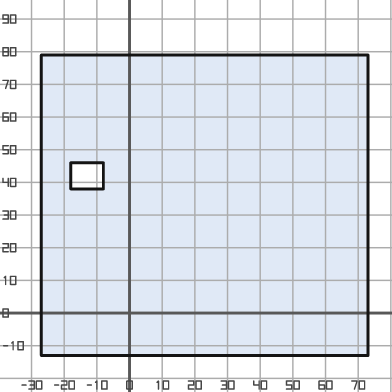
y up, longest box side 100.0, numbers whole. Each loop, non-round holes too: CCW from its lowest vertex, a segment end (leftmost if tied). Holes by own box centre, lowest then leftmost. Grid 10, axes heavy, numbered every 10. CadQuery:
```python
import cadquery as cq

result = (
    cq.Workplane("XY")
    .moveTo(-27.0, -13.0)
    .lineTo(73.0, -13.0)
    .lineTo(73.0, 79.0)
    .lineTo(-27.0, 79.0)
    .close()
    .moveTo(-18.0, 38.0)
    .lineTo(-8.0, 38.0)
    .lineTo(-8.0, 46.0)
    .lineTo(-18.0, 46.0)
    .close()
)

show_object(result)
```